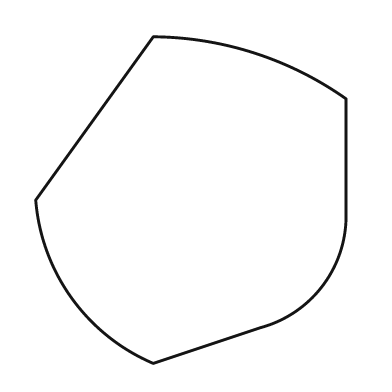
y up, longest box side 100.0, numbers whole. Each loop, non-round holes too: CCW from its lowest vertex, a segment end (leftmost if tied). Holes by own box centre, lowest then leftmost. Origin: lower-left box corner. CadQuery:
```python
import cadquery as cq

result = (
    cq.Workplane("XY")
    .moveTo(36.0, 0.0)
    .lineTo(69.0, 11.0)
    .threePointArc((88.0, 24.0), (95.0, 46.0))
    .lineTo(95.0, 81.0)
    .threePointArc((67.0, 95.0), (36.0, 100.0))
    .lineTo(0.0, 50.0)
    .threePointArc((11.0, 20.0), (36.0, 0.0))
    .close()
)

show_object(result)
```